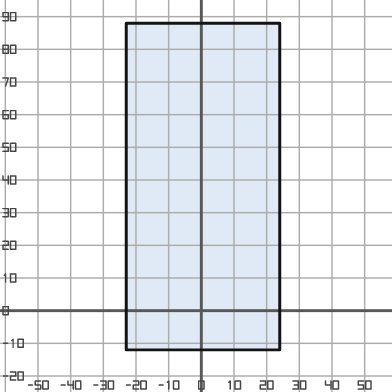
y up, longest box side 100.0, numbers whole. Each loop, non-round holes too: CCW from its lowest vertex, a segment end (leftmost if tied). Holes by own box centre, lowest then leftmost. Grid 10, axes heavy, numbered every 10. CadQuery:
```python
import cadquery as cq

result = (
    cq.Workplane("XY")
    .moveTo(-23.0, -12.0)
    .lineTo(24.0, -12.0)
    .lineTo(24.0, 88.0)
    .lineTo(-23.0, 88.0)
    .close()
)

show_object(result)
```